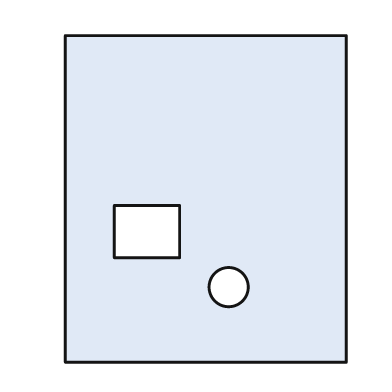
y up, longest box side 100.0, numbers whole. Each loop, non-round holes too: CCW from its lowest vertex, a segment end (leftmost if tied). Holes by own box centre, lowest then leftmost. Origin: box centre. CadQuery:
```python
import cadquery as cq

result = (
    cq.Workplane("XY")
    .moveTo(-43.0, -50.0)
    .lineTo(43.0, -50.0)
    .lineTo(43.0, 50.0)
    .lineTo(-43.0, 50.0)
    .close()
    .moveTo(7.0, -27.0)
    .circle(6.0)
    .moveTo(-28.0, -18.0)
    .lineTo(-8.0, -18.0)
    .lineTo(-8.0, -2.0)
    .lineTo(-28.0, -2.0)
    .close()
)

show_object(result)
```